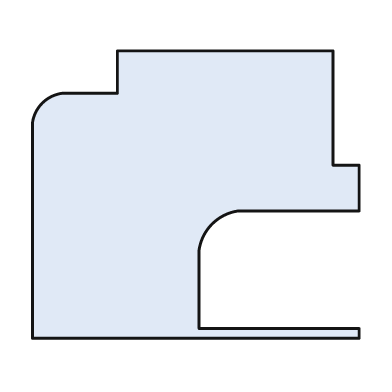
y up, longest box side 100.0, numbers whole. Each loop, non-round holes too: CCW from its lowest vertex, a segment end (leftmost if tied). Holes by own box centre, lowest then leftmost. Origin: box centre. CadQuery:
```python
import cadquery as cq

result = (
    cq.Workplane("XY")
    .moveTo(-50.0, -44.0)
    .lineTo(50.0, -44.0)
    .lineTo(50.0, -41.0)
    .lineTo(1.0, -41.0)
    .lineTo(1.0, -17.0)
    .threePointArc((5.0, -9.0), (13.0, -5.0))
    .lineTo(50.0, -5.0)
    .lineTo(50.0, 9.0)
    .lineTo(42.0, 9.0)
    .lineTo(42.0, 44.0)
    .lineTo(-24.0, 44.0)
    .lineTo(-24.0, 31.0)
    .lineTo(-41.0, 31.0)
    .threePointArc((-47.0, 28.0), (-50.0, 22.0))
    .close()
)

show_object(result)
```